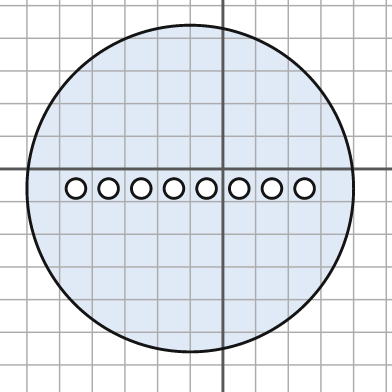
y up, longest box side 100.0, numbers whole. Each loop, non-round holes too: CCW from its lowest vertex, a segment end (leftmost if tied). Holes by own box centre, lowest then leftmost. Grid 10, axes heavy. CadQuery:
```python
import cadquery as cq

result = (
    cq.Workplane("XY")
    .moveTo(-10.0, -6.0)
    .circle(50.0)
    .moveTo(-45.0, -6.0)
    .circle(3.0)
    .moveTo(-35.0, -6.0)
    .circle(3.0)
    .moveTo(-25.0, -6.0)
    .circle(3.0)
    .moveTo(-15.0, -6.0)
    .circle(3.0)
    .moveTo(-5.0, -6.0)
    .circle(3.0)
    .moveTo(5.0, -6.0)
    .circle(3.0)
    .moveTo(15.0, -6.0)
    .circle(3.0)
    .moveTo(25.0, -6.0)
    .circle(3.0)
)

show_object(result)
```